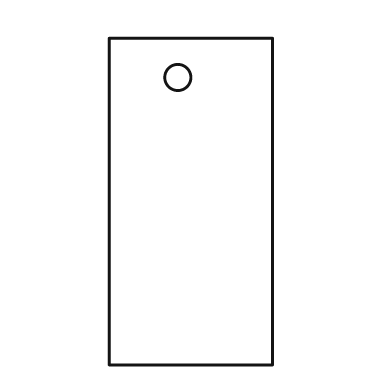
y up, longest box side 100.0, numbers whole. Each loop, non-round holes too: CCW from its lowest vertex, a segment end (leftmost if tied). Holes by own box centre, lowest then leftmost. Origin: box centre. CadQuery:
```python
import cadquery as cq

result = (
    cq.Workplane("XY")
    .moveTo(-25.0, -50.0)
    .lineTo(25.0, -50.0)
    .lineTo(25.0, 50.0)
    .lineTo(-25.0, 50.0)
    .close()
    .moveTo(-4.0, 38.0)
    .circle(4.0)
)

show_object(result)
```